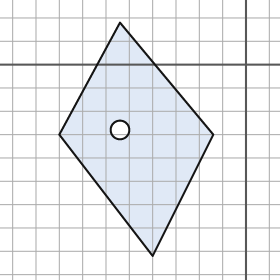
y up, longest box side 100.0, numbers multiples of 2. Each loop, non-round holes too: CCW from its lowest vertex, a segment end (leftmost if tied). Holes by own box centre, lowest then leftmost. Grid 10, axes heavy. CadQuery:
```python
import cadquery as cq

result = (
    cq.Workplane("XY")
    .moveTo(-40.0, -82.0)
    .lineTo(-14.0, -30.0)
    .lineTo(-54.0, 18.0)
    .lineTo(-80.0, -30.0)
    .close()
    .moveTo(-54.0, -28.0)
    .circle(4.0)
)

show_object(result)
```